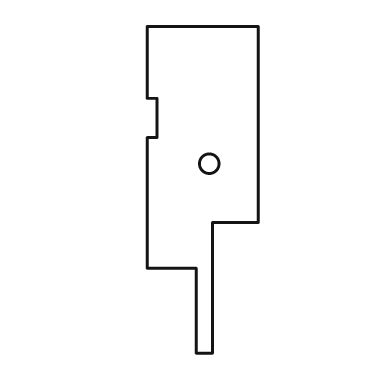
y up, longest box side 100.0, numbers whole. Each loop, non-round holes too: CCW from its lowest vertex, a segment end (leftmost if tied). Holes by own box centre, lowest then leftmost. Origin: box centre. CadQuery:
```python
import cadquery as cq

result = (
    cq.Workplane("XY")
    .moveTo(-2.0, -50.0)
    .lineTo(3.0, -50.0)
    .lineTo(3.0, -10.0)
    .lineTo(17.0, -10.0)
    .lineTo(17.0, 50.0)
    .lineTo(-17.0, 50.0)
    .lineTo(-17.0, 28.0)
    .lineTo(-14.0, 28.0)
    .lineTo(-14.0, 16.0)
    .lineTo(-17.0, 16.0)
    .lineTo(-17.0, -24.0)
    .lineTo(-2.0, -24.0)
    .close()
    .moveTo(2.0, 8.0)
    .circle(3.0)
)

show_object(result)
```